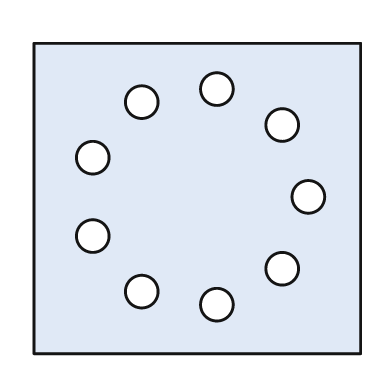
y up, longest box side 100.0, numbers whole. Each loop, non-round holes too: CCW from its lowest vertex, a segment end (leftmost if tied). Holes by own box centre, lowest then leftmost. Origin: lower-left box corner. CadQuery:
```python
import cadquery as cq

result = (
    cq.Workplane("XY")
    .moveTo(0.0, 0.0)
    .lineTo(100.0, 0.0)
    .lineTo(100.0, 95.0)
    .lineTo(0.0, 95.0)
    .close()
    .moveTo(56.0, 15.0)
    .circle(5.0)
    .moveTo(33.0, 19.0)
    .circle(5.0)
    .moveTo(76.0, 26.0)
    .circle(5.0)
    .moveTo(18.0, 36.0)
    .circle(5.0)
    .moveTo(84.0, 48.0)
    .circle(5.0)
    .moveTo(18.0, 60.0)
    .circle(5.0)
    .moveTo(76.0, 70.0)
    .circle(5.0)
    .moveTo(33.0, 77.0)
    .circle(5.0)
    .moveTo(56.0, 81.0)
    .circle(5.0)
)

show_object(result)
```